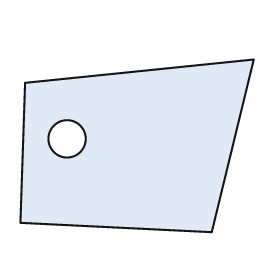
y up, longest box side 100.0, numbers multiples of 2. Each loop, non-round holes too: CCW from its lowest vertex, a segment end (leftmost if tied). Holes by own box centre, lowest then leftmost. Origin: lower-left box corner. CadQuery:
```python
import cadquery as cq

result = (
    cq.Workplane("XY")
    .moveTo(82.0, 0.0)
    .lineTo(100.0, 74.0)
    .lineTo(2.0, 64.0)
    .lineTo(0.0, 4.0)
    .close()
    .moveTo(20.0, 40.0)
    .circle(8.0)
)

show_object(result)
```